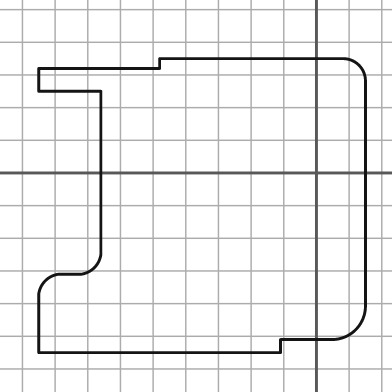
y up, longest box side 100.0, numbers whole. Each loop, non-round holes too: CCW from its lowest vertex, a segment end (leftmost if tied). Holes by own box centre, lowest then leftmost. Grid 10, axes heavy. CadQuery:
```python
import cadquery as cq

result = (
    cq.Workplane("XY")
    .moveTo(-85.0, -55.0)
    .lineTo(-11.0, -55.0)
    .lineTo(-11.0, -51.0)
    .lineTo(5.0, -51.0)
    .threePointArc((12.0, -48.0), (15.0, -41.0))
    .lineTo(15.0, 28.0)
    .threePointArc((13.0, 33.0), (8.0, 35.0))
    .lineTo(-48.0, 35.0)
    .lineTo(-48.0, 32.0)
    .lineTo(-85.0, 32.0)
    .lineTo(-85.0, 25.0)
    .lineTo(-66.0, 25.0)
    .lineTo(-66.0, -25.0)
    .threePointArc((-68.0, -29.0), (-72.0, -31.0))
    .lineTo(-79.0, -31.0)
    .threePointArc((-83.0, -33.0), (-85.0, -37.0))
    .close()
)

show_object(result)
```